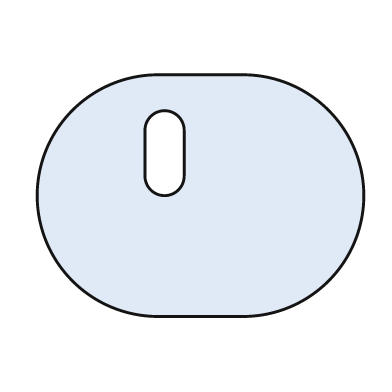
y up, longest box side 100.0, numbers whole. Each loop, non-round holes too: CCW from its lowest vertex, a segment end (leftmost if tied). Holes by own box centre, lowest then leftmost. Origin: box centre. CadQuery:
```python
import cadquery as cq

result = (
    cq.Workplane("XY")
    .moveTo(-13.0, -37.0)
    .lineTo(13.0, -37.0)
    .threePointArc((50.0, 0.0), (13.0, 37.0))
    .lineTo(-13.0, 37.0)
    .threePointArc((-50.0, 0.0), (-13.0, -37.0))
    .close()
    .moveTo(-17.0, 6.0)
    .threePointArc((-11.0, 0.0), (-5.0, 6.0))
    .lineTo(-5.0, 20.0)
    .threePointArc((-11.0, 26.0), (-17.0, 20.0))
    .close()
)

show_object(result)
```